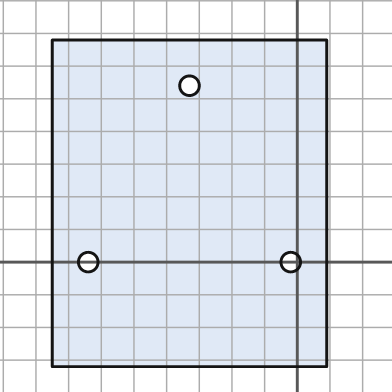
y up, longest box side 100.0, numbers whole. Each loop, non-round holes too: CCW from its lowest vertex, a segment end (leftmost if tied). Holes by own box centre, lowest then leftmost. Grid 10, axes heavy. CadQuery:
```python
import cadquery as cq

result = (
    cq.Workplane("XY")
    .moveTo(-75.0, -32.0)
    .lineTo(9.0, -32.0)
    .lineTo(9.0, 68.0)
    .lineTo(-75.0, 68.0)
    .close()
    .moveTo(-64.0, 0.0)
    .circle(3.0)
    .moveTo(-2.0, 0.0)
    .circle(3.0)
    .moveTo(-33.0, 54.0)
    .circle(3.0)
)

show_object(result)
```